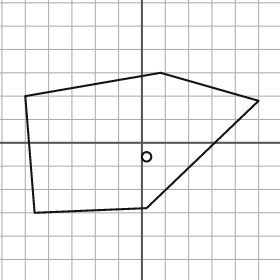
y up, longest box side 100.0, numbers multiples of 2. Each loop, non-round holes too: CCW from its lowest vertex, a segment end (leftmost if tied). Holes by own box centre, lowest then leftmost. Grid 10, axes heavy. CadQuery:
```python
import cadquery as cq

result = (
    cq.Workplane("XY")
    .moveTo(-46.0, -30.0)
    .lineTo(2.0, -28.0)
    .lineTo(50.0, 18.0)
    .lineTo(8.0, 30.0)
    .lineTo(-50.0, 20.0)
    .close()
    .moveTo(2.0, -6.0)
    .circle(2.0)
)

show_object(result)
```